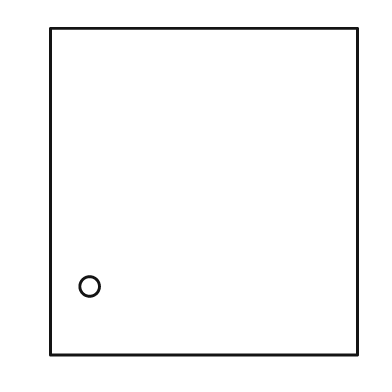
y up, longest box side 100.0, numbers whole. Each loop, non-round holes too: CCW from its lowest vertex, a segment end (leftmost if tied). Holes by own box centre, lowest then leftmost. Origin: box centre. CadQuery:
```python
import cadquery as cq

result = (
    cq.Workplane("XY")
    .moveTo(-47.0, -50.0)
    .lineTo(47.0, -50.0)
    .lineTo(47.0, 50.0)
    .lineTo(-47.0, 50.0)
    .close()
    .moveTo(-35.0, -29.0)
    .circle(3.0)
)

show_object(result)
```